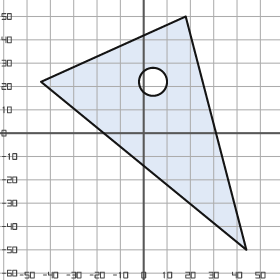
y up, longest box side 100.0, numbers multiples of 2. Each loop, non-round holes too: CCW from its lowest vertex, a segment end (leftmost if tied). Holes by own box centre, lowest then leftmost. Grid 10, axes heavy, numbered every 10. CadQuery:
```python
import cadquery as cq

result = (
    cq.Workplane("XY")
    .moveTo(44.0, -50.0)
    .lineTo(18.0, 50.0)
    .lineTo(-44.0, 22.0)
    .close()
    .moveTo(4.0, 22.0)
    .circle(6.0)
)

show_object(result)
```